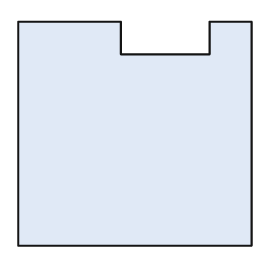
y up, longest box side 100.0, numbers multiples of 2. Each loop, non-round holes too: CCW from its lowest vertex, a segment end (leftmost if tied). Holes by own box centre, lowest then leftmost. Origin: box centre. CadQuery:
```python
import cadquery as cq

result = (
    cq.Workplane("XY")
    .moveTo(-50.0, -48.0)
    .lineTo(50.0, -48.0)
    .lineTo(50.0, 48.0)
    .lineTo(32.0, 48.0)
    .lineTo(32.0, 34.0)
    .lineTo(-6.0, 34.0)
    .lineTo(-6.0, 48.0)
    .lineTo(-50.0, 48.0)
    .close()
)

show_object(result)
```